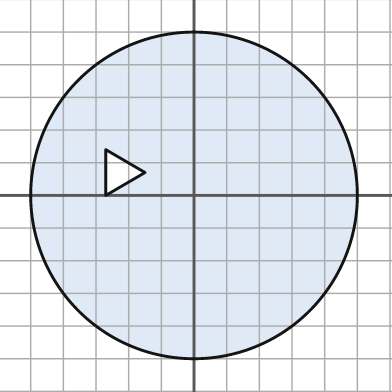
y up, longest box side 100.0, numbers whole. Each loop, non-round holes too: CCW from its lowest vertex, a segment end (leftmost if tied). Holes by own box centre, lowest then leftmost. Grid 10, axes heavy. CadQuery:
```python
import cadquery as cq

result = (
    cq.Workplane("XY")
    .moveTo(0.0, 0.0)
    .circle(50.0)
    .moveTo(-27.0, 0.0)
    .lineTo(-15.0, 7.0)
    .lineTo(-27.0, 14.0)
    .close()
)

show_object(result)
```